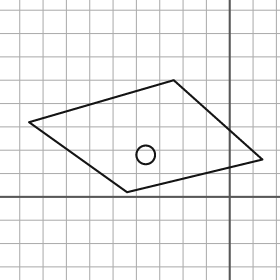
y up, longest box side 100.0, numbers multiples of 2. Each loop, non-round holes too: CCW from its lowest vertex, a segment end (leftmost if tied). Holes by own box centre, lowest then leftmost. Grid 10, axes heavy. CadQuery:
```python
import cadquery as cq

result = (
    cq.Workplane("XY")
    .moveTo(-44.0, 2.0)
    .lineTo(14.0, 16.0)
    .lineTo(-24.0, 50.0)
    .lineTo(-86.0, 32.0)
    .close()
    .moveTo(-36.0, 18.0)
    .circle(4.0)
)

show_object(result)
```